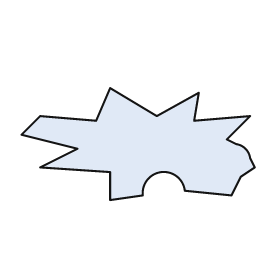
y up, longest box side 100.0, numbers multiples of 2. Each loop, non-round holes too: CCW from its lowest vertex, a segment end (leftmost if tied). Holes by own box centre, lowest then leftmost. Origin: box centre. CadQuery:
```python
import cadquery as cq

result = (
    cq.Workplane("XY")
    .moveTo(-12.0, -24.0)
    .lineTo(2.0, -22.0)
    .threePointArc((10.0, -12.0), (20.0, -20.0))
    .lineTo(40.0, -22.0)
    .lineTo(44.0, -14.0)
    .lineTo(50.0, -10.0)
    .lineTo(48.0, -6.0)
    .threePointArc((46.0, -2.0), (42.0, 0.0))
    .lineTo(38.0, 2.0)
    .lineTo(48.0, 12.0)
    .lineTo(24.0, 10.0)
    .lineTo(26.0, 22.0)
    .lineTo(8.0, 12.0)
    .lineTo(-12.0, 24.0)
    .lineTo(-18.0, 10.0)
    .lineTo(-42.0, 12.0)
    .lineTo(-50.0, 4.0)
    .lineTo(-26.0, -2.0)
    .lineTo(-42.0, -10.0)
    .lineTo(-12.0, -12.0)
    .close()
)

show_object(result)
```